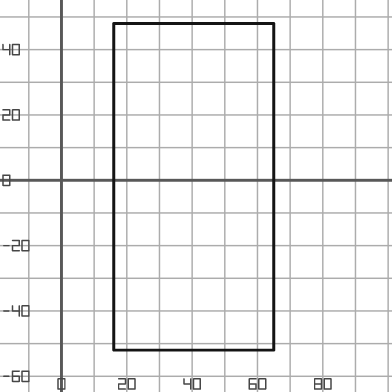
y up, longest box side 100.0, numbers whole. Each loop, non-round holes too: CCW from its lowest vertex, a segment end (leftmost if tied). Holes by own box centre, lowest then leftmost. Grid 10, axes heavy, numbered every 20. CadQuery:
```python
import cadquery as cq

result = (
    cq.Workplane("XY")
    .moveTo(16.0, -52.0)
    .lineTo(65.0, -52.0)
    .lineTo(65.0, 48.0)
    .lineTo(16.0, 48.0)
    .close()
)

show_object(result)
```